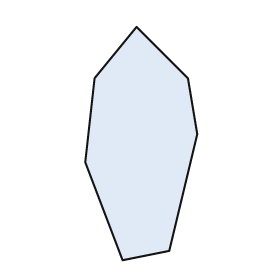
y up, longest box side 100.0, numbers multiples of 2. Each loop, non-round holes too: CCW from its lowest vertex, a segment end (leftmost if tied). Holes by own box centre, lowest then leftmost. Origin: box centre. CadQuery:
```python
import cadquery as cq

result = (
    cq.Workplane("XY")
    .moveTo(-8.0, -50.0)
    .lineTo(12.0, -46.0)
    .lineTo(24.0, 4.0)
    .lineTo(20.0, 28.0)
    .lineTo(-2.0, 50.0)
    .lineTo(-20.0, 28.0)
    .lineTo(-24.0, -8.0)
    .close()
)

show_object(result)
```